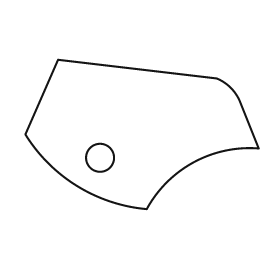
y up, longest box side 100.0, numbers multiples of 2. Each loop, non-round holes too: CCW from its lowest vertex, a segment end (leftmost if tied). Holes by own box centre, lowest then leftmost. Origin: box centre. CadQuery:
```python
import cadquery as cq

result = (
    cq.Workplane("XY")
    .moveTo(2.0, -32.0)
    .threePointArc((22.0, -12.0), (50.0, -6.0))
    .lineTo(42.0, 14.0)
    .threePointArc((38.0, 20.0), (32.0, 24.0))
    .lineTo(-36.0, 32.0)
    .lineTo(-50.0, 0.0)
    .threePointArc((-28.0, -22.0), (2.0, -32.0))
    .close()
    .moveTo(-18.0, -10.0)
    .circle(6.0)
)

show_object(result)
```